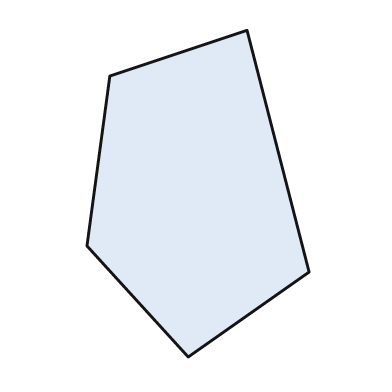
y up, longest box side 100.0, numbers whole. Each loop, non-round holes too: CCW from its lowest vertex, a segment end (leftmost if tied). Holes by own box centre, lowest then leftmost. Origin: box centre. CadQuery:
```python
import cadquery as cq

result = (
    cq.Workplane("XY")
    .moveTo(-3.0, -50.0)
    .lineTo(34.0, -24.0)
    .lineTo(15.0, 50.0)
    .lineTo(-27.0, 36.0)
    .lineTo(-34.0, -16.0)
    .close()
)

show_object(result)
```